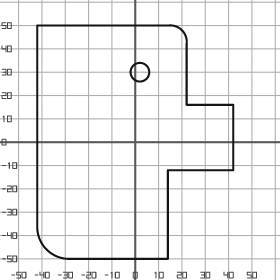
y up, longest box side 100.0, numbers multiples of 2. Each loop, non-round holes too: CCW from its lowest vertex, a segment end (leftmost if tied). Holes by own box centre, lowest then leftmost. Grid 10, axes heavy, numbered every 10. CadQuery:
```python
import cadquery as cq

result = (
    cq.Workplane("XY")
    .moveTo(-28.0, -50.0)
    .lineTo(14.0, -50.0)
    .lineTo(14.0, -12.0)
    .lineTo(42.0, -12.0)
    .lineTo(42.0, 16.0)
    .lineTo(22.0, 16.0)
    .lineTo(22.0, 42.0)
    .threePointArc((20.0, 48.0), (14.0, 50.0))
    .lineTo(-42.0, 50.0)
    .lineTo(-42.0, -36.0)
    .threePointArc((-38.0, -46.0), (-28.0, -50.0))
    .close()
    .moveTo(2.0, 30.0)
    .circle(4.0)
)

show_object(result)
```